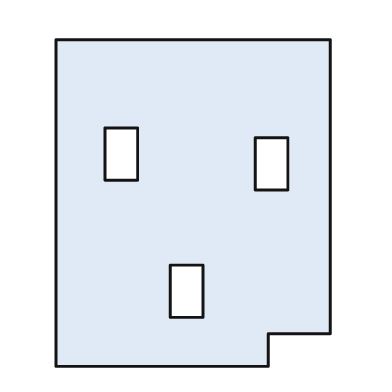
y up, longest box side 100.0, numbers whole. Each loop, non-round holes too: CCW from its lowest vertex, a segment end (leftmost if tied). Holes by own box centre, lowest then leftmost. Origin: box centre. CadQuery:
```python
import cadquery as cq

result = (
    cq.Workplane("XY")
    .moveTo(-42.0, -50.0)
    .lineTo(23.0, -50.0)
    .lineTo(23.0, -40.0)
    .lineTo(42.0, -40.0)
    .lineTo(42.0, 50.0)
    .lineTo(-42.0, 50.0)
    .close()
    .moveTo(-7.0, -35.0)
    .lineTo(3.0, -35.0)
    .lineTo(3.0, -19.0)
    .lineTo(-7.0, -19.0)
    .close()
    .moveTo(19.0, 4.0)
    .lineTo(29.0, 4.0)
    .lineTo(29.0, 20.0)
    .lineTo(19.0, 20.0)
    .close()
    .moveTo(-27.0, 7.0)
    .lineTo(-17.0, 7.0)
    .lineTo(-17.0, 23.0)
    .lineTo(-27.0, 23.0)
    .close()
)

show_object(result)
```